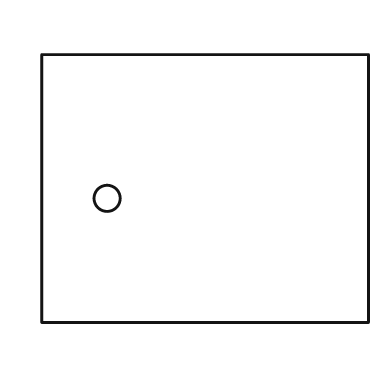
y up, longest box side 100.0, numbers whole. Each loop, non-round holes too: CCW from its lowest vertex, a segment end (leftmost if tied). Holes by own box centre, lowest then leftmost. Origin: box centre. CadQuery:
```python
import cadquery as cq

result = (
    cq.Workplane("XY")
    .moveTo(-50.0, -41.0)
    .lineTo(50.0, -41.0)
    .lineTo(50.0, 41.0)
    .lineTo(-50.0, 41.0)
    .close()
    .moveTo(-30.0, -3.0)
    .circle(4.0)
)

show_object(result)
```